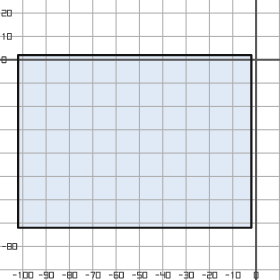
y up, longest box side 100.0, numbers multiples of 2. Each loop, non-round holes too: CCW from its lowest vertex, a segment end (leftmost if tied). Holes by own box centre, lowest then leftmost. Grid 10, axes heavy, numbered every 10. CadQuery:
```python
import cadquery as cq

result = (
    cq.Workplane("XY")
    .moveTo(-102.0, -72.0)
    .lineTo(-2.0, -72.0)
    .lineTo(-2.0, 2.0)
    .lineTo(-102.0, 2.0)
    .close()
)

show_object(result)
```